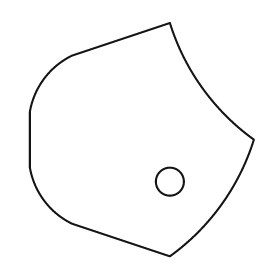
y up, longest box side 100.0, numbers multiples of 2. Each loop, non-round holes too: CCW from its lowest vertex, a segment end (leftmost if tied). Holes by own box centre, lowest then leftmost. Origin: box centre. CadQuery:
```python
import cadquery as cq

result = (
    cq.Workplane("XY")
    .moveTo(12.0, -50.0)
    .threePointArc((34.0, -28.0), (48.0, 0.0))
    .threePointArc((26.0, 22.0), (12.0, 50.0))
    .lineTo(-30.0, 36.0)
    .threePointArc((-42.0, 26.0), (-48.0, 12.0))
    .lineTo(-48.0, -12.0)
    .threePointArc((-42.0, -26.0), (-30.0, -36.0))
    .close()
    .moveTo(12.0, -18.0)
    .circle(6.0)
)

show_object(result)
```